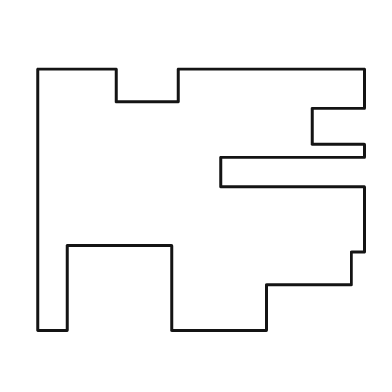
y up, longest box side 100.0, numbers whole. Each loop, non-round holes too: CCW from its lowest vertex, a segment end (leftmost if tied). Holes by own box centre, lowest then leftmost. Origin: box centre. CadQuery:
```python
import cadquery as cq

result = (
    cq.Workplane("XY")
    .moveTo(-50.0, -40.0)
    .lineTo(-41.0, -40.0)
    .lineTo(-41.0, -14.0)
    .lineTo(-9.0, -14.0)
    .lineTo(-9.0, -40.0)
    .lineTo(20.0, -40.0)
    .lineTo(20.0, -26.0)
    .lineTo(46.0, -26.0)
    .lineTo(46.0, -16.0)
    .lineTo(50.0, -16.0)
    .lineTo(50.0, 4.0)
    .lineTo(6.0, 4.0)
    .lineTo(6.0, 13.0)
    .lineTo(50.0, 13.0)
    .lineTo(50.0, 17.0)
    .lineTo(34.0, 17.0)
    .lineTo(34.0, 28.0)
    .lineTo(50.0, 28.0)
    .lineTo(50.0, 40.0)
    .lineTo(-7.0, 40.0)
    .lineTo(-7.0, 30.0)
    .lineTo(-26.0, 30.0)
    .lineTo(-26.0, 40.0)
    .lineTo(-50.0, 40.0)
    .close()
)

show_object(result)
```